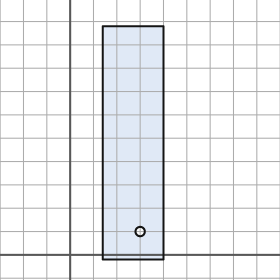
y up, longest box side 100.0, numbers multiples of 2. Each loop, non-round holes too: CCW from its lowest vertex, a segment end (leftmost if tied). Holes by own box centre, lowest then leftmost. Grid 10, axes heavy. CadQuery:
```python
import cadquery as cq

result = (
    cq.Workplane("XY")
    .moveTo(14.0, -2.0)
    .lineTo(40.0, -2.0)
    .lineTo(40.0, 98.0)
    .lineTo(14.0, 98.0)
    .close()
    .moveTo(30.0, 10.0)
    .circle(2.0)
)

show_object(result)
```